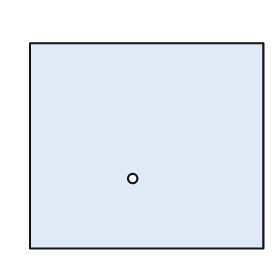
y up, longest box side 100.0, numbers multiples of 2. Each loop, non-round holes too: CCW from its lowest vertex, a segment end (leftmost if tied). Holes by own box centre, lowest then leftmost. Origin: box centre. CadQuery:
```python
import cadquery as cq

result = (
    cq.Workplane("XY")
    .moveTo(-50.0, -44.0)
    .lineTo(50.0, -44.0)
    .lineTo(50.0, 44.0)
    .lineTo(-50.0, 44.0)
    .close()
    .moveTo(-6.0, -14.0)
    .circle(2.0)
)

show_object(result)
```